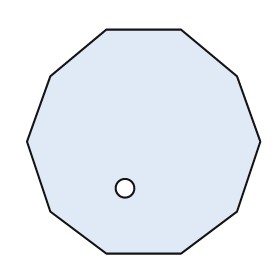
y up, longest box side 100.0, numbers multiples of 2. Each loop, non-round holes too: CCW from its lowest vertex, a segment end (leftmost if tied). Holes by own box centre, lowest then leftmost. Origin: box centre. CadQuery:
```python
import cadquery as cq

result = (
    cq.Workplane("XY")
    .moveTo(-16.0, -48.0)
    .lineTo(16.0, -48.0)
    .lineTo(40.0, -30.0)
    .lineTo(50.0, 0.0)
    .lineTo(40.0, 28.0)
    .lineTo(16.0, 48.0)
    .lineTo(-16.0, 48.0)
    .lineTo(-40.0, 28.0)
    .lineTo(-50.0, 0.0)
    .lineTo(-40.0, -30.0)
    .close()
    .moveTo(-8.0, -20.0)
    .circle(4.0)
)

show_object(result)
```